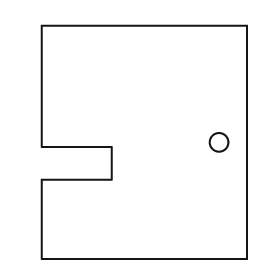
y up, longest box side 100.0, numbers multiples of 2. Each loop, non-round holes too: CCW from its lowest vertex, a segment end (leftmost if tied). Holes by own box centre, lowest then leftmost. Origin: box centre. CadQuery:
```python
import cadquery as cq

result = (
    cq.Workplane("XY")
    .moveTo(-44.0, -50.0)
    .lineTo(44.0, -50.0)
    .lineTo(44.0, 50.0)
    .lineTo(-44.0, 50.0)
    .lineTo(-44.0, -2.0)
    .lineTo(-14.0, -2.0)
    .lineTo(-14.0, -16.0)
    .lineTo(-44.0, -16.0)
    .close()
    .moveTo(32.0, 0.0)
    .circle(4.0)
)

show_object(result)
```